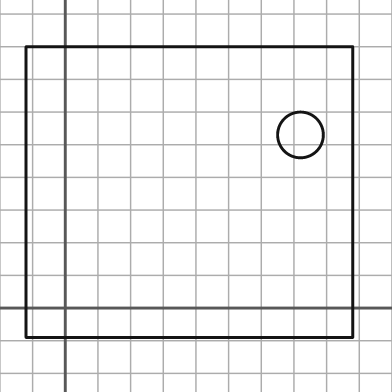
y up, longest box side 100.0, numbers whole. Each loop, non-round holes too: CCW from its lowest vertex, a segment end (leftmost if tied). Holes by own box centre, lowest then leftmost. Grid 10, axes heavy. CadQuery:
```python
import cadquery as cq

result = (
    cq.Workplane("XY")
    .moveTo(-12.0, -9.0)
    .lineTo(88.0, -9.0)
    .lineTo(88.0, 80.0)
    .lineTo(-12.0, 80.0)
    .close()
    .moveTo(72.0, 53.0)
    .circle(7.0)
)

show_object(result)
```